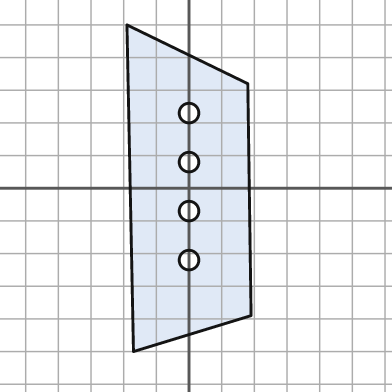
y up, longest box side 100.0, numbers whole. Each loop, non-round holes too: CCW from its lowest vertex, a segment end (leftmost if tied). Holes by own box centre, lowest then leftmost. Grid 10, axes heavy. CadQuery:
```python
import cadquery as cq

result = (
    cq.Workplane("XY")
    .moveTo(-17.0, -50.0)
    .lineTo(19.0, -39.0)
    .lineTo(18.0, 32.0)
    .lineTo(-19.0, 50.0)
    .close()
    .moveTo(0.0, -22.0)
    .circle(3.0)
    .moveTo(0.0, -7.0)
    .circle(3.0)
    .moveTo(0.0, 8.0)
    .circle(3.0)
    .moveTo(0.0, 23.0)
    .circle(3.0)
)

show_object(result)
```